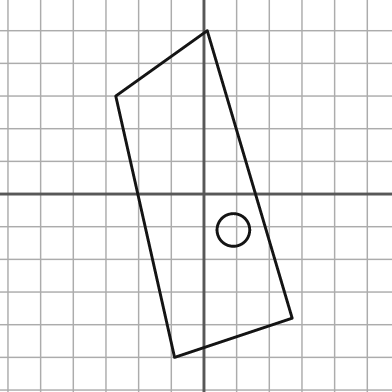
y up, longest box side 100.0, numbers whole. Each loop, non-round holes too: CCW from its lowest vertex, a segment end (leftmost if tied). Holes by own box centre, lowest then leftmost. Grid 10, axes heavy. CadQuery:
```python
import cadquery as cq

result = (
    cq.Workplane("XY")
    .moveTo(-9.0, -50.0)
    .lineTo(27.0, -38.0)
    .lineTo(1.0, 50.0)
    .lineTo(-27.0, 30.0)
    .close()
    .moveTo(9.0, -11.0)
    .circle(5.0)
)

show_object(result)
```